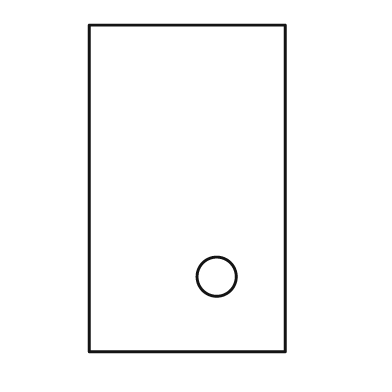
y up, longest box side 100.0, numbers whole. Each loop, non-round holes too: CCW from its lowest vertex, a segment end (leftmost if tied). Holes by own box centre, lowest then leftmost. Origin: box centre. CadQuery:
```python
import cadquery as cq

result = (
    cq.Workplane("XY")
    .moveTo(-30.0, -50.0)
    .lineTo(30.0, -50.0)
    .lineTo(30.0, 50.0)
    .lineTo(-30.0, 50.0)
    .close()
    .moveTo(9.0, -27.0)
    .circle(6.0)
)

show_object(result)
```